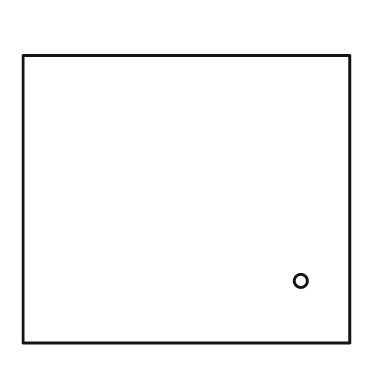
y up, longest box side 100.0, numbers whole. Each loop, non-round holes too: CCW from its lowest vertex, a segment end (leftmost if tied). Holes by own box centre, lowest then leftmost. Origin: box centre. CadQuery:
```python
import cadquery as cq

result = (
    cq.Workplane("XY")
    .moveTo(-50.0, -44.0)
    .lineTo(50.0, -44.0)
    .lineTo(50.0, 44.0)
    .lineTo(-50.0, 44.0)
    .close()
    .moveTo(35.0, -25.0)
    .circle(2.0)
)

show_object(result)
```